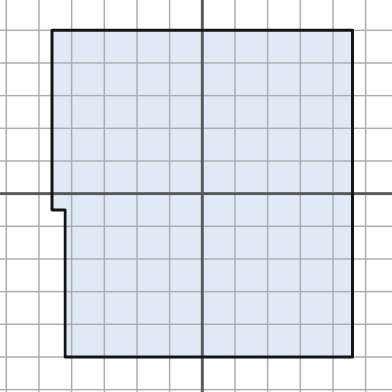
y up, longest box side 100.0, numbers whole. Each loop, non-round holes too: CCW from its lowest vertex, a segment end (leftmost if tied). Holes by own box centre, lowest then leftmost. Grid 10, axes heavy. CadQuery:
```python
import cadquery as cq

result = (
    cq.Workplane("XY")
    .moveTo(-42.0, -50.0)
    .lineTo(46.0, -50.0)
    .lineTo(46.0, 50.0)
    .lineTo(-46.0, 50.0)
    .lineTo(-46.0, -5.0)
    .lineTo(-42.0, -5.0)
    .close()
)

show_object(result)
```